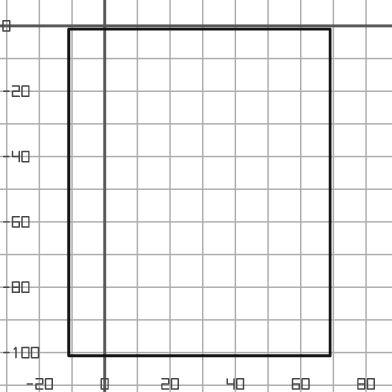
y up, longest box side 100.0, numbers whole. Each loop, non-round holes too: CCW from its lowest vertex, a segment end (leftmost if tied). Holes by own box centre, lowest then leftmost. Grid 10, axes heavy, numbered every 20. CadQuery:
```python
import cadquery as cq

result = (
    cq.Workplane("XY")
    .moveTo(-11.0, -101.0)
    .lineTo(69.0, -101.0)
    .lineTo(69.0, -1.0)
    .lineTo(-11.0, -1.0)
    .close()
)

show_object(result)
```